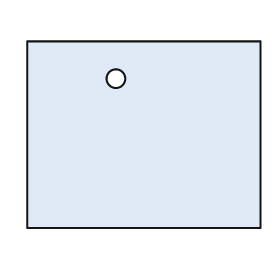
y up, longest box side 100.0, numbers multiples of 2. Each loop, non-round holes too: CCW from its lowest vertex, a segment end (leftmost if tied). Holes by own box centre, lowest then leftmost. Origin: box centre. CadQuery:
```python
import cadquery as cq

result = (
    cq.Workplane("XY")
    .moveTo(-50.0, -40.0)
    .lineTo(50.0, -40.0)
    .lineTo(50.0, 40.0)
    .lineTo(-50.0, 40.0)
    .close()
    .moveTo(-12.0, 24.0)
    .circle(4.0)
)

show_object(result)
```